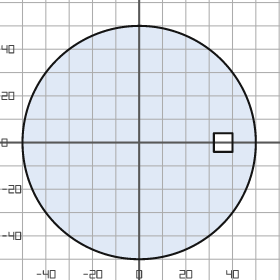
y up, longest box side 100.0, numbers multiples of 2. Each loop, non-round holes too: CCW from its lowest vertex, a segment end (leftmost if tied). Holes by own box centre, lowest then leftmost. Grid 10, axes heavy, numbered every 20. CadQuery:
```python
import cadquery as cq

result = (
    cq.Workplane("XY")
    .moveTo(0.0, 0.0)
    .circle(50.0)
    .moveTo(32.0, -4.0)
    .lineTo(40.0, -4.0)
    .lineTo(40.0, 4.0)
    .lineTo(32.0, 4.0)
    .close()
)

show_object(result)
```